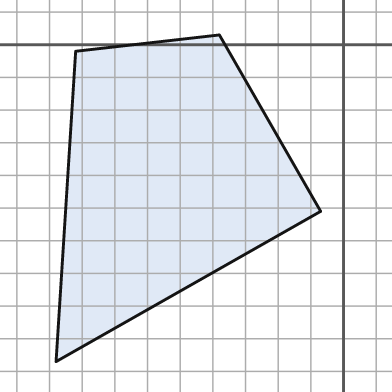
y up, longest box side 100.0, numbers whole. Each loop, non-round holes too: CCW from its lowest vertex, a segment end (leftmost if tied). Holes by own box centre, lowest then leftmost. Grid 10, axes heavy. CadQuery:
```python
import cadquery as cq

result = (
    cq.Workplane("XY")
    .moveTo(-88.0, -97.0)
    .lineTo(-7.0, -51.0)
    .lineTo(-38.0, 3.0)
    .lineTo(-82.0, -2.0)
    .close()
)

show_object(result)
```